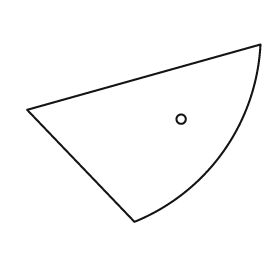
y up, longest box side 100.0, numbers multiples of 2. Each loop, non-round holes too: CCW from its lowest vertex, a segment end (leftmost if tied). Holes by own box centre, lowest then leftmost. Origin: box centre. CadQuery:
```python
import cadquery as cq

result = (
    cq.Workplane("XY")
    .moveTo(-4.0, -38.0)
    .threePointArc((34.0, -8.0), (50.0, 38.0))
    .lineTo(-50.0, 10.0)
    .close()
    .moveTo(16.0, 6.0)
    .circle(2.0)
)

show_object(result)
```